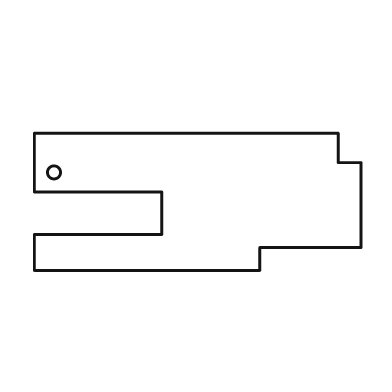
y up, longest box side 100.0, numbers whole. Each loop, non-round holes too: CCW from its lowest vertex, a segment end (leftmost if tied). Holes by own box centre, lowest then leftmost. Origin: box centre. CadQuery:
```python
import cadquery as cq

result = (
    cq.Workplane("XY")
    .moveTo(-50.0, -21.0)
    .lineTo(19.0, -21.0)
    .lineTo(19.0, -14.0)
    .lineTo(50.0, -14.0)
    .lineTo(50.0, 12.0)
    .lineTo(43.0, 12.0)
    .lineTo(43.0, 21.0)
    .lineTo(-50.0, 21.0)
    .lineTo(-50.0, 3.0)
    .lineTo(-11.0, 3.0)
    .lineTo(-11.0, -10.0)
    .lineTo(-50.0, -10.0)
    .close()
    .moveTo(-44.0, 9.0)
    .circle(2.0)
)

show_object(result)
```